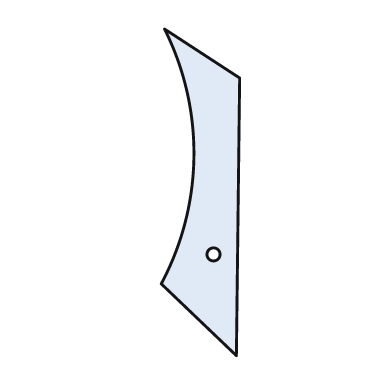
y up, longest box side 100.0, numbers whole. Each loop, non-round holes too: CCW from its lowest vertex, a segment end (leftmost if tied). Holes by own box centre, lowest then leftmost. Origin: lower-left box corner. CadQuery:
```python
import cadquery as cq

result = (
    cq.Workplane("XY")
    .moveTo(23.0, 0.0)
    .lineTo(24.0, 85.0)
    .lineTo(1.0, 100.0)
    .threePointArc((10.0, 61.0), (0.0, 22.0))
    .close()
    .moveTo(16.0, 31.0)
    .circle(2.0)
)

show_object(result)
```